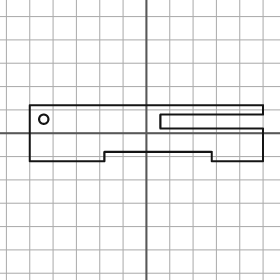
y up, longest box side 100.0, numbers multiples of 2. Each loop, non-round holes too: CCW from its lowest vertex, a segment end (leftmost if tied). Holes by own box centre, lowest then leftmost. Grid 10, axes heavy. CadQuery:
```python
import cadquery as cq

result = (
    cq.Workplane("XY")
    .moveTo(-50.0, -12.0)
    .lineTo(-18.0, -12.0)
    .lineTo(-18.0, -8.0)
    .lineTo(28.0, -8.0)
    .lineTo(28.0, -12.0)
    .lineTo(50.0, -12.0)
    .lineTo(50.0, 2.0)
    .lineTo(6.0, 2.0)
    .lineTo(6.0, 8.0)
    .lineTo(50.0, 8.0)
    .lineTo(50.0, 12.0)
    .lineTo(-50.0, 12.0)
    .close()
    .moveTo(-44.0, 6.0)
    .circle(2.0)
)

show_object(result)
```